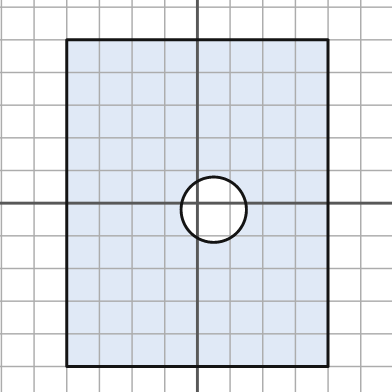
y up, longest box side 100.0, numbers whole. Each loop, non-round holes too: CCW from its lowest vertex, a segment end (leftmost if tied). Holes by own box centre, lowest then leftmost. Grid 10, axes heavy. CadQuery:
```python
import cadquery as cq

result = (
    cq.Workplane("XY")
    .moveTo(-40.0, -50.0)
    .lineTo(40.0, -50.0)
    .lineTo(40.0, 50.0)
    .lineTo(-40.0, 50.0)
    .close()
    .moveTo(5.0, -2.0)
    .circle(10.0)
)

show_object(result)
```